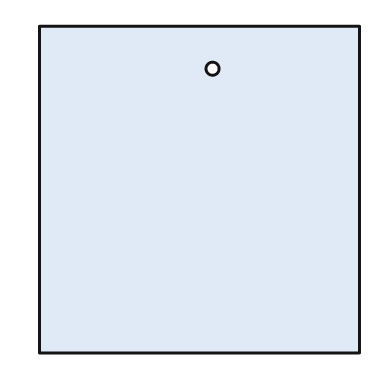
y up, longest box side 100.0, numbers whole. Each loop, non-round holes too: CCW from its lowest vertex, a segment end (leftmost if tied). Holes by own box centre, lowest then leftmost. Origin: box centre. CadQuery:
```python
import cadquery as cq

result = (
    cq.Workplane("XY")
    .moveTo(-49.0, -50.0)
    .lineTo(49.0, -50.0)
    .lineTo(49.0, 50.0)
    .lineTo(-49.0, 50.0)
    .close()
    .moveTo(4.0, 37.0)
    .circle(2.0)
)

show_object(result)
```